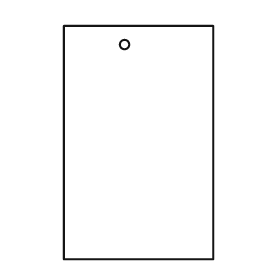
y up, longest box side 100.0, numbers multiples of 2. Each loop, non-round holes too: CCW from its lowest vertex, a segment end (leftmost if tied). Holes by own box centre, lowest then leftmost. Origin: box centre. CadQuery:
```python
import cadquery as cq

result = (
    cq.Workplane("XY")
    .moveTo(-32.0, -50.0)
    .lineTo(32.0, -50.0)
    .lineTo(32.0, 50.0)
    .lineTo(-32.0, 50.0)
    .close()
    .moveTo(-6.0, 42.0)
    .circle(2.0)
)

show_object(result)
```